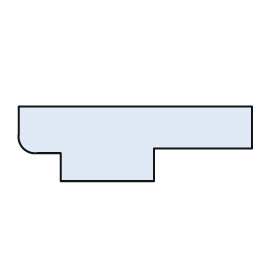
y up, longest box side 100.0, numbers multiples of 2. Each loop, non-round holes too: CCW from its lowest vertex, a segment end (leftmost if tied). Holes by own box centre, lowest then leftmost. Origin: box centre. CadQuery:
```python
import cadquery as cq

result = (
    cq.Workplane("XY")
    .moveTo(-32.0, -16.0)
    .lineTo(8.0, -16.0)
    .lineTo(8.0, -2.0)
    .lineTo(50.0, -2.0)
    .lineTo(50.0, 16.0)
    .lineTo(-50.0, 16.0)
    .lineTo(-50.0, 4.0)
    .threePointArc((-48.0, -2.0), (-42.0, -4.0))
    .lineTo(-32.0, -4.0)
    .close()
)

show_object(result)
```